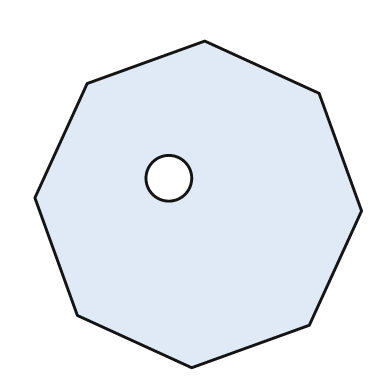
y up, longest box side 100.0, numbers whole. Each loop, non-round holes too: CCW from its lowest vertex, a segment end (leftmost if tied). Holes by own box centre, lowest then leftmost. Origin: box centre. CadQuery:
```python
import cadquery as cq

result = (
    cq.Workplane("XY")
    .moveTo(-2.0, -50.0)
    .lineTo(34.0, -37.0)
    .lineTo(50.0, -2.0)
    .lineTo(37.0, 34.0)
    .lineTo(2.0, 50.0)
    .lineTo(-34.0, 37.0)
    .lineTo(-50.0, 2.0)
    .lineTo(-37.0, -34.0)
    .close()
    .moveTo(-9.0, 8.0)
    .circle(7.0)
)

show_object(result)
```